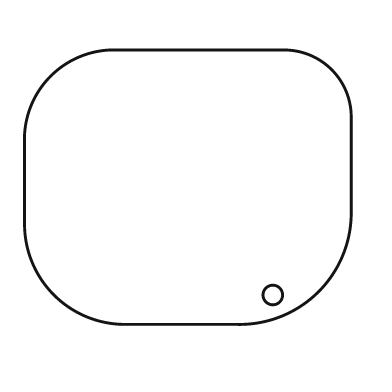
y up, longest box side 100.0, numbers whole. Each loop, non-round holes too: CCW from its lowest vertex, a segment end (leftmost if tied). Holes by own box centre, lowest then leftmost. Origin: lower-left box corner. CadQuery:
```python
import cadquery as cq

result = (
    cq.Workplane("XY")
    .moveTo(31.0, 0.0)
    .lineTo(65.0, 0.0)
    .threePointArc((90.0, 10.0), (100.0, 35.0))
    .lineTo(100.0, 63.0)
    .threePointArc((94.0, 78.0), (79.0, 84.0))
    .lineTo(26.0, 84.0)
    .threePointArc((8.0, 76.0), (0.0, 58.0))
    .lineTo(0.0, 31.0)
    .threePointArc((9.0, 9.0), (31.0, 0.0))
    .close()
    .moveTo(76.0, 9.0)
    .circle(3.0)
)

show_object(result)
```